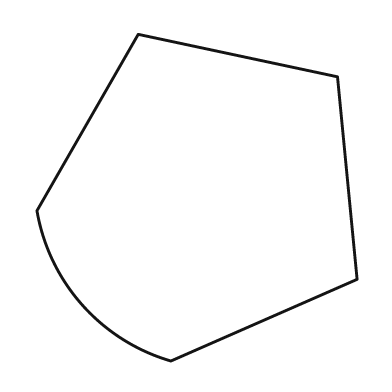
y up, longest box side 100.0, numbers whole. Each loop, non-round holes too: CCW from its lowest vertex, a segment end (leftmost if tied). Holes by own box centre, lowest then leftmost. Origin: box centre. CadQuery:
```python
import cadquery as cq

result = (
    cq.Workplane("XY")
    .moveTo(-8.0, -50.0)
    .lineTo(49.0, -25.0)
    .lineTo(43.0, 37.0)
    .lineTo(-18.0, 50.0)
    .lineTo(-49.0, -4.0)
    .threePointArc((-35.0, -33.0), (-8.0, -50.0))
    .close()
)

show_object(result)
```